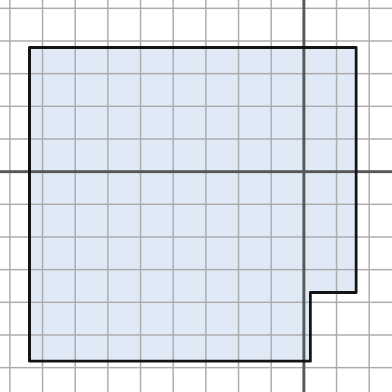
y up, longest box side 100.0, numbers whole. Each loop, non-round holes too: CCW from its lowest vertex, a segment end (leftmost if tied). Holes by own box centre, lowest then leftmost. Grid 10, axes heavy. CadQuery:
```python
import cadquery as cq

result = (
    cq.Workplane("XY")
    .moveTo(-84.0, -58.0)
    .lineTo(2.0, -58.0)
    .lineTo(2.0, -37.0)
    .lineTo(16.0, -37.0)
    .lineTo(16.0, 38.0)
    .lineTo(-84.0, 38.0)
    .close()
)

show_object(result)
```